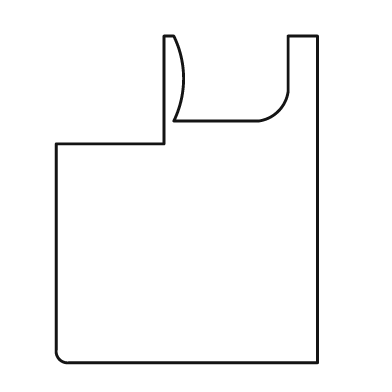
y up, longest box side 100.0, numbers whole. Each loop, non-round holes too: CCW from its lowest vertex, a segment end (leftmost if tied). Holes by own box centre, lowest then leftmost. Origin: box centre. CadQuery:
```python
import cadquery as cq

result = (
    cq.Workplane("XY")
    .moveTo(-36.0, -50.0)
    .lineTo(40.0, -50.0)
    .lineTo(40.0, 50.0)
    .lineTo(31.0, 50.0)
    .lineTo(31.0, 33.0)
    .threePointArc((28.0, 27.0), (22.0, 24.0))
    .lineTo(-4.0, 24.0)
    .threePointArc((-1.0, 37.0), (-4.0, 50.0))
    .lineTo(-7.0, 50.0)
    .lineTo(-7.0, 17.0)
    .lineTo(-40.0, 17.0)
    .lineTo(-40.0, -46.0)
    .threePointArc((-39.0, -49.0), (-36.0, -50.0))
    .close()
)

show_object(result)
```